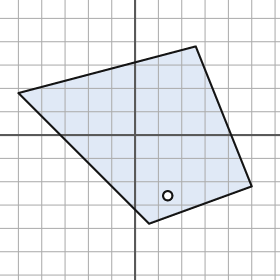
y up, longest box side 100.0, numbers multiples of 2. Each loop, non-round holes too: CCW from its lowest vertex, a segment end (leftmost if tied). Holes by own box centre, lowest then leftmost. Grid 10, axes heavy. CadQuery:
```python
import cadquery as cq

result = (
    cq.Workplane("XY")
    .moveTo(6.0, -38.0)
    .lineTo(50.0, -22.0)
    .lineTo(26.0, 38.0)
    .lineTo(-50.0, 18.0)
    .close()
    .moveTo(14.0, -26.0)
    .circle(2.0)
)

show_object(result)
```